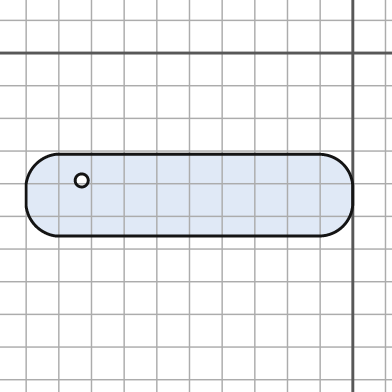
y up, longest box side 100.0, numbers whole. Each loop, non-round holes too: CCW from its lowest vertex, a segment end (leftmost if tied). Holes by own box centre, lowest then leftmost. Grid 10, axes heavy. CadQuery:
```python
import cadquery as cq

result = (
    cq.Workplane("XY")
    .moveTo(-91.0, -56.0)
    .lineTo(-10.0, -56.0)
    .threePointArc((-3.0, -53.0), (0.0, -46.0))
    .lineTo(0.0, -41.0)
    .threePointArc((-3.0, -34.0), (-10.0, -31.0))
    .lineTo(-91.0, -31.0)
    .threePointArc((-97.0, -34.0), (-100.0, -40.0))
    .lineTo(-100.0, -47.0)
    .threePointArc((-97.0, -53.0), (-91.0, -56.0))
    .close()
    .moveTo(-83.0, -39.0)
    .circle(2.0)
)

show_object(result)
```